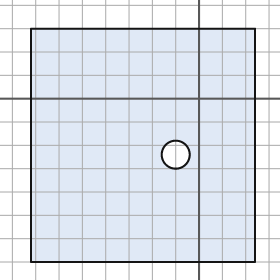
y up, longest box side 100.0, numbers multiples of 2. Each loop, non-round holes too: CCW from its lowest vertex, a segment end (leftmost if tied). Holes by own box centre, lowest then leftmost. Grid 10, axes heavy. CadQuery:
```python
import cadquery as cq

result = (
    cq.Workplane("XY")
    .moveTo(-72.0, -70.0)
    .lineTo(24.0, -70.0)
    .lineTo(24.0, 30.0)
    .lineTo(-72.0, 30.0)
    .close()
    .moveTo(-10.0, -24.0)
    .circle(6.0)
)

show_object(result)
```